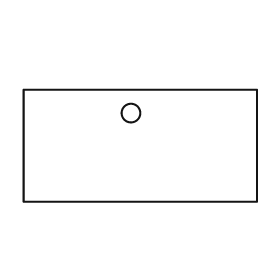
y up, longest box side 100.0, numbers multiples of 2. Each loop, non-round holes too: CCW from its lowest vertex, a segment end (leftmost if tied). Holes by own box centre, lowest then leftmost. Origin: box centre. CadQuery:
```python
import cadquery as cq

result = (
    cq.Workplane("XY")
    .moveTo(-50.0, -24.0)
    .lineTo(50.0, -24.0)
    .lineTo(50.0, 24.0)
    .lineTo(-50.0, 24.0)
    .close()
    .moveTo(-4.0, 14.0)
    .circle(4.0)
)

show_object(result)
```